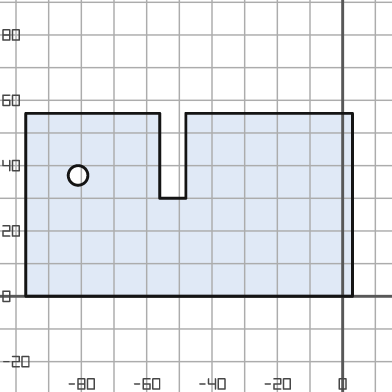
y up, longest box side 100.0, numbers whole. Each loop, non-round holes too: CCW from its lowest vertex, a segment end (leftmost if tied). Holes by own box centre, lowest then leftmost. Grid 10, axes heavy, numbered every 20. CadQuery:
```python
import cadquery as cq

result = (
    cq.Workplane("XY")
    .moveTo(-97.0, 0.0)
    .lineTo(3.0, 0.0)
    .lineTo(3.0, 56.0)
    .lineTo(-48.0, 56.0)
    .lineTo(-48.0, 30.0)
    .lineTo(-56.0, 30.0)
    .lineTo(-56.0, 56.0)
    .lineTo(-97.0, 56.0)
    .close()
    .moveTo(-81.0, 37.0)
    .circle(3.0)
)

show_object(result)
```